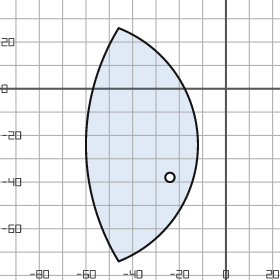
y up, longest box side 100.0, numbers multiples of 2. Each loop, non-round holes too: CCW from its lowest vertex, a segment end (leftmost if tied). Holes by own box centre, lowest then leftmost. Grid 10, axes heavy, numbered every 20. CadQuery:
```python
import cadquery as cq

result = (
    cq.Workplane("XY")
    .moveTo(-46.0, -74.0)
    .threePointArc((-12.0, -24.0), (-46.0, 26.0))
    .threePointArc((-60.0, -24.0), (-46.0, -74.0))
    .close()
    .moveTo(-24.0, -38.0)
    .circle(2.0)
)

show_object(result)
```